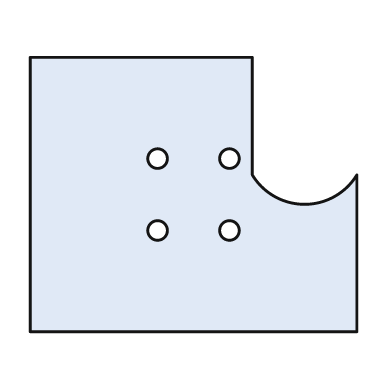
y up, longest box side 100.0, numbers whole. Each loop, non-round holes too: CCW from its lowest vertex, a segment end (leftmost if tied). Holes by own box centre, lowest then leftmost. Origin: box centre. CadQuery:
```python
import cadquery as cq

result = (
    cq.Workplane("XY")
    .moveTo(-50.0, -42.0)
    .lineTo(50.0, -42.0)
    .lineTo(50.0, 6.0)
    .threePointArc((34.0, -3.0), (18.0, 6.0))
    .lineTo(18.0, 42.0)
    .lineTo(-50.0, 42.0)
    .close()
    .moveTo(-11.0, -11.0)
    .circle(3.0)
    .moveTo(11.0, -11.0)
    .circle(3.0)
    .moveTo(-11.0, 11.0)
    .circle(3.0)
    .moveTo(11.0, 11.0)
    .circle(3.0)
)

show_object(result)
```